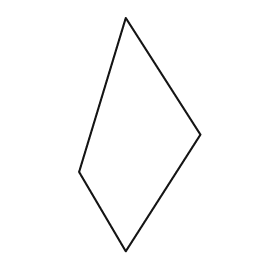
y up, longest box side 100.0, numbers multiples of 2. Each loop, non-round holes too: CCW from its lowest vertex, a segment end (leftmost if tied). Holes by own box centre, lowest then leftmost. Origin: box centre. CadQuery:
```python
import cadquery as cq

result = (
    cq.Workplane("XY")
    .moveTo(-6.0, -50.0)
    .lineTo(26.0, 0.0)
    .lineTo(-6.0, 50.0)
    .lineTo(-26.0, -16.0)
    .close()
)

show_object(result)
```